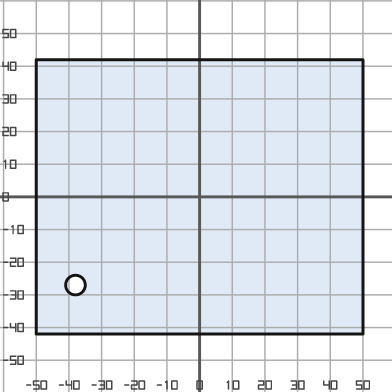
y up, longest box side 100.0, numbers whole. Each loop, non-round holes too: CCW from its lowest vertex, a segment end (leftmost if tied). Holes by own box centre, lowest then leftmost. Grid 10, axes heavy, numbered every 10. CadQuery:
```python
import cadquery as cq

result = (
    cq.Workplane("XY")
    .moveTo(-50.0, -42.0)
    .lineTo(50.0, -42.0)
    .lineTo(50.0, 42.0)
    .lineTo(-50.0, 42.0)
    .close()
    .moveTo(-38.0, -27.0)
    .circle(3.0)
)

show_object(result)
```